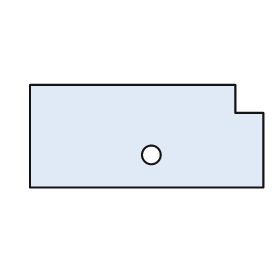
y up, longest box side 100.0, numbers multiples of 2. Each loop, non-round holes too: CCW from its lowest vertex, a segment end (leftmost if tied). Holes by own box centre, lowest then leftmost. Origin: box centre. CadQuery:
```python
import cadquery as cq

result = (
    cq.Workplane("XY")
    .moveTo(-50.0, -22.0)
    .lineTo(50.0, -22.0)
    .lineTo(50.0, 10.0)
    .lineTo(38.0, 10.0)
    .lineTo(38.0, 22.0)
    .lineTo(-50.0, 22.0)
    .close()
    .moveTo(2.0, -8.0)
    .circle(4.0)
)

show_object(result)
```